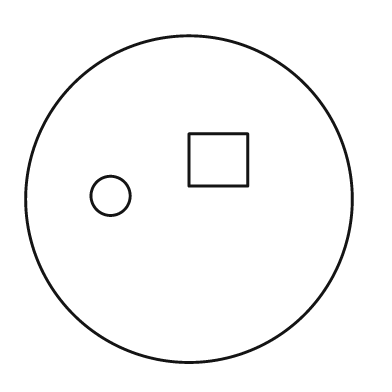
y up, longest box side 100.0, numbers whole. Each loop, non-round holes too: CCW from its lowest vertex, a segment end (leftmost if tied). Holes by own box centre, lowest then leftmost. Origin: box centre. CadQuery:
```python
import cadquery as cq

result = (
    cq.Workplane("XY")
    .moveTo(0.0, 0.0)
    .circle(50.0)
    .moveTo(-24.0, 1.0)
    .circle(6.0)
    .moveTo(0.0, 4.0)
    .lineTo(18.0, 4.0)
    .lineTo(18.0, 20.0)
    .lineTo(0.0, 20.0)
    .close()
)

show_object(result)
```